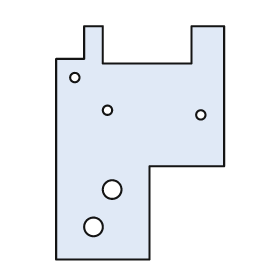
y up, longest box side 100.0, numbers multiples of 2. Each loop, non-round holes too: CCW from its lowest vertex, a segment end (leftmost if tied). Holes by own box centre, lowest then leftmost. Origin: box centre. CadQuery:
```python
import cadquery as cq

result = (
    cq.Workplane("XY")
    .moveTo(-36.0, -50.0)
    .lineTo(4.0, -50.0)
    .lineTo(4.0, -10.0)
    .lineTo(36.0, -10.0)
    .lineTo(36.0, 50.0)
    .lineTo(22.0, 50.0)
    .lineTo(22.0, 34.0)
    .lineTo(-16.0, 34.0)
    .lineTo(-16.0, 50.0)
    .lineTo(-24.0, 50.0)
    .lineTo(-24.0, 36.0)
    .lineTo(-36.0, 36.0)
    .close()
    .moveTo(-20.0, -36.0)
    .circle(4.0)
    .moveTo(-12.0, -20.0)
    .circle(4.0)
    .moveTo(26.0, 12.0)
    .circle(2.0)
    .moveTo(-14.0, 14.0)
    .circle(2.0)
    .moveTo(-28.0, 28.0)
    .circle(2.0)
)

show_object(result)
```